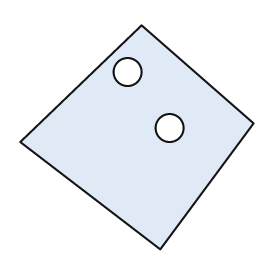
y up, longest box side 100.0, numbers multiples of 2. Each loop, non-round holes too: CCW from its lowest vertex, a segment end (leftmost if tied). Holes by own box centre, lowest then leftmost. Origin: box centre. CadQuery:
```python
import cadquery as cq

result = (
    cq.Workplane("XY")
    .moveTo(10.0, -48.0)
    .lineTo(50.0, 6.0)
    .lineTo(2.0, 48.0)
    .lineTo(-50.0, -2.0)
    .close()
    .moveTo(14.0, 4.0)
    .circle(6.0)
    .moveTo(-4.0, 28.0)
    .circle(6.0)
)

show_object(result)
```